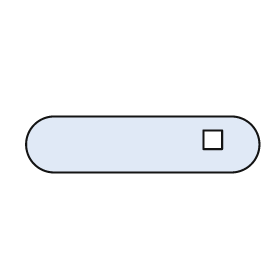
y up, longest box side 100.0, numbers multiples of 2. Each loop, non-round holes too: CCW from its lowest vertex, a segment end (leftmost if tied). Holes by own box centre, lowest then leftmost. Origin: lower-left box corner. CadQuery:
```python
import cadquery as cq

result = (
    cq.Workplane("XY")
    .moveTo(12.0, 0.0)
    .lineTo(88.0, 0.0)
    .threePointArc((100.0, 12.0), (88.0, 24.0))
    .lineTo(12.0, 24.0)
    .threePointArc((0.0, 12.0), (12.0, 0.0))
    .close()
    .moveTo(76.0, 10.0)
    .lineTo(84.0, 10.0)
    .lineTo(84.0, 18.0)
    .lineTo(76.0, 18.0)
    .close()
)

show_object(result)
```